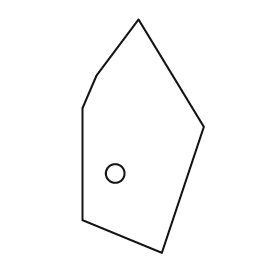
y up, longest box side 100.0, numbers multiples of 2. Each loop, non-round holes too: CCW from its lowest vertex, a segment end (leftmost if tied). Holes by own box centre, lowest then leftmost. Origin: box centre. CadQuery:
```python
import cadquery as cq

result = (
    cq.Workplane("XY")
    .moveTo(8.0, -50.0)
    .lineTo(26.0, 4.0)
    .lineTo(-2.0, 50.0)
    .lineTo(-20.0, 26.0)
    .lineTo(-26.0, 12.0)
    .lineTo(-26.0, -36.0)
    .close()
    .moveTo(-12.0, -16.0)
    .circle(4.0)
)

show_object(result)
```